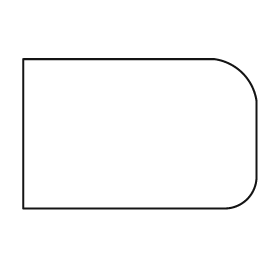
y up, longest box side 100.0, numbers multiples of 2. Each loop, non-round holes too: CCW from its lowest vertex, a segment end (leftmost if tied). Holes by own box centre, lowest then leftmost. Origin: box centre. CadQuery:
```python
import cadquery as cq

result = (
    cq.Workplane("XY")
    .moveTo(-50.0, -32.0)
    .lineTo(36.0, -32.0)
    .threePointArc((46.0, -28.0), (50.0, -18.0))
    .lineTo(50.0, 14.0)
    .threePointArc((44.0, 26.0), (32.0, 32.0))
    .lineTo(-50.0, 32.0)
    .close()
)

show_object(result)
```